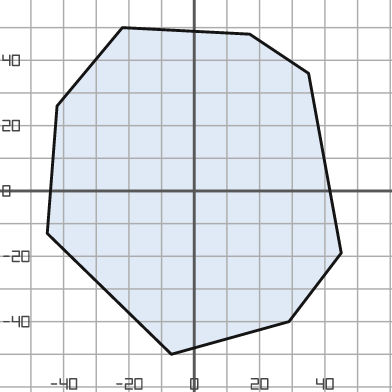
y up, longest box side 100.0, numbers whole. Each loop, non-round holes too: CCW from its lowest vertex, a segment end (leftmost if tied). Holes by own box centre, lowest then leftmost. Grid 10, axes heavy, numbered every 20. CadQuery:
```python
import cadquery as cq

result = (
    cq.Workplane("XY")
    .moveTo(-7.0, -50.0)
    .lineTo(29.0, -40.0)
    .lineTo(45.0, -19.0)
    .lineTo(35.0, 36.0)
    .lineTo(17.0, 48.0)
    .lineTo(-22.0, 50.0)
    .lineTo(-42.0, 26.0)
    .lineTo(-45.0, -13.0)
    .close()
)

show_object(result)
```